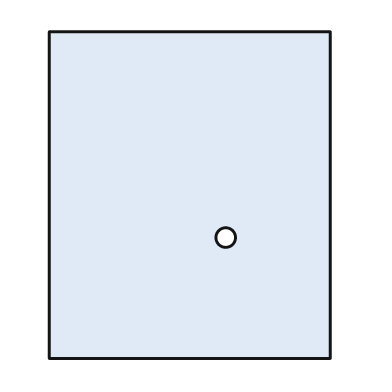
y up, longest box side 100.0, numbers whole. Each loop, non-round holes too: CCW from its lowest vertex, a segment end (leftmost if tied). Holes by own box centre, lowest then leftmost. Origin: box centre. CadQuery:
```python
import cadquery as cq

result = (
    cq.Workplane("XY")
    .moveTo(-43.0, -50.0)
    .lineTo(43.0, -50.0)
    .lineTo(43.0, 50.0)
    .lineTo(-43.0, 50.0)
    .close()
    .moveTo(11.0, -13.0)
    .circle(3.0)
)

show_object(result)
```